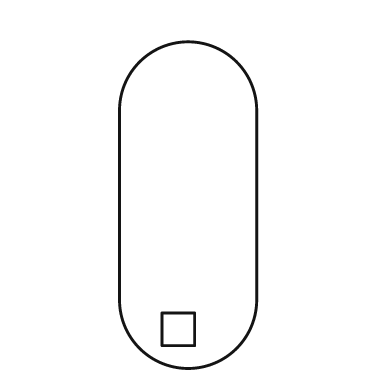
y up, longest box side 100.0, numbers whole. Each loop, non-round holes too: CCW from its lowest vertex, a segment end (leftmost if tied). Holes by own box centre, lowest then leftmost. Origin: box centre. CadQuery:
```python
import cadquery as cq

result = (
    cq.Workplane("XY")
    .moveTo(-21.0, -29.0)
    .threePointArc((0.0, -50.0), (21.0, -29.0))
    .lineTo(21.0, 29.0)
    .threePointArc((0.0, 50.0), (-21.0, 29.0))
    .close()
    .moveTo(-8.0, -43.0)
    .lineTo(2.0, -43.0)
    .lineTo(2.0, -33.0)
    .lineTo(-8.0, -33.0)
    .close()
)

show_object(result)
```